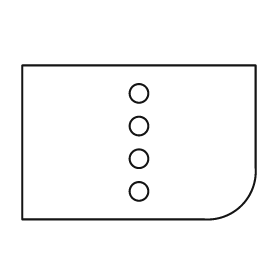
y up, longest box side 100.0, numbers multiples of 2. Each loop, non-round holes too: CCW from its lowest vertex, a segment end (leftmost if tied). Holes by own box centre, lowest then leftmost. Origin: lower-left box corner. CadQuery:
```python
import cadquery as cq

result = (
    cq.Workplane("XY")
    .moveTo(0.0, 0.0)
    .lineTo(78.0, 0.0)
    .threePointArc((94.0, 6.0), (100.0, 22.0))
    .lineTo(100.0, 66.0)
    .lineTo(0.0, 66.0)
    .close()
    .moveTo(50.0, 12.0)
    .circle(4.0)
    .moveTo(50.0, 26.0)
    .circle(4.0)
    .moveTo(50.0, 40.0)
    .circle(4.0)
    .moveTo(50.0, 54.0)
    .circle(4.0)
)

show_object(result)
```